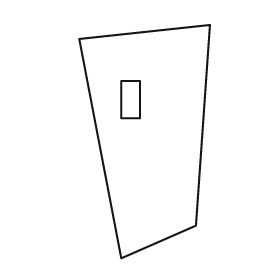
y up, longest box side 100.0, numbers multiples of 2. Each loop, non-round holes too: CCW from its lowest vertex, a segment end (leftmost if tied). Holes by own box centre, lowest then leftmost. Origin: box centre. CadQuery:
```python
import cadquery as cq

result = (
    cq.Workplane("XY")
    .moveTo(-10.0, -50.0)
    .lineTo(22.0, -36.0)
    .lineTo(28.0, 50.0)
    .lineTo(-28.0, 44.0)
    .close()
    .moveTo(-10.0, 10.0)
    .lineTo(-2.0, 10.0)
    .lineTo(-2.0, 26.0)
    .lineTo(-10.0, 26.0)
    .close()
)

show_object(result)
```